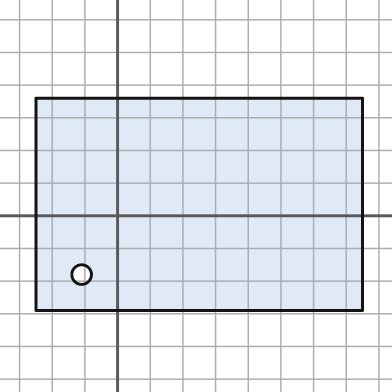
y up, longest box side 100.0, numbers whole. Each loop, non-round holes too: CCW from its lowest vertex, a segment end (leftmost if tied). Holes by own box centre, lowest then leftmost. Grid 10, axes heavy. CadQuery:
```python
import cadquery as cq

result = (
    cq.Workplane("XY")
    .moveTo(-25.0, -29.0)
    .lineTo(75.0, -29.0)
    .lineTo(75.0, 36.0)
    .lineTo(-25.0, 36.0)
    .close()
    .moveTo(-11.0, -18.0)
    .circle(3.0)
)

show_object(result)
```